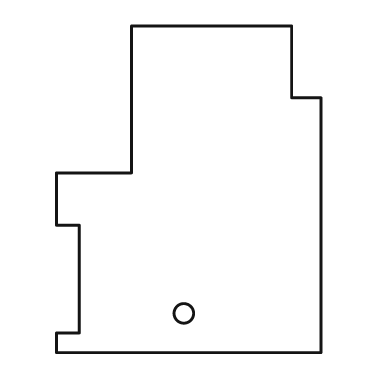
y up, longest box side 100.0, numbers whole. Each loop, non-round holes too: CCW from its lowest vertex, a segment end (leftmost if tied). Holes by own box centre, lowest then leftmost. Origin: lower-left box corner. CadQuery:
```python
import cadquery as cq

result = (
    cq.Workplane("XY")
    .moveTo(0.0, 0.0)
    .lineTo(81.0, 0.0)
    .lineTo(81.0, 78.0)
    .lineTo(72.0, 78.0)
    .lineTo(72.0, 100.0)
    .lineTo(23.0, 100.0)
    .lineTo(23.0, 55.0)
    .lineTo(0.0, 55.0)
    .lineTo(0.0, 39.0)
    .lineTo(7.0, 39.0)
    .lineTo(7.0, 6.0)
    .lineTo(0.0, 6.0)
    .close()
    .moveTo(39.0, 12.0)
    .circle(3.0)
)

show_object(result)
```